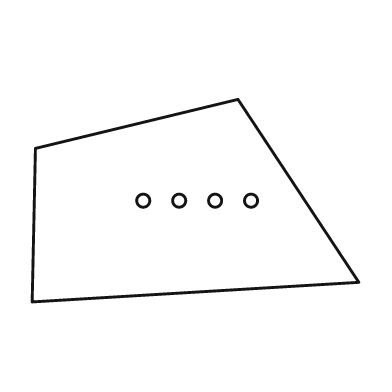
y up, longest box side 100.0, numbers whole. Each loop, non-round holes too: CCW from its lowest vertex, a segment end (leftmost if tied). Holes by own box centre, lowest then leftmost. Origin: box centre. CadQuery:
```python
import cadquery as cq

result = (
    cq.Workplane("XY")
    .moveTo(-50.0, -31.0)
    .lineTo(50.0, -25.0)
    .lineTo(13.0, 31.0)
    .lineTo(-49.0, 16.0)
    .close()
    .moveTo(-16.0, 0.0)
    .circle(2.0)
    .moveTo(-5.0, 0.0)
    .circle(2.0)
    .moveTo(6.0, 0.0)
    .circle(2.0)
    .moveTo(17.0, 0.0)
    .circle(2.0)
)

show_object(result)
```